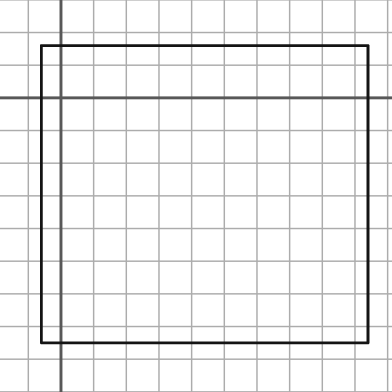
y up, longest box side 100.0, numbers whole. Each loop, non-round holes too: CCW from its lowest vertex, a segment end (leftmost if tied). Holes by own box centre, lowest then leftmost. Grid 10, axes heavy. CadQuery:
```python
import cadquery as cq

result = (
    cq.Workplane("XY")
    .moveTo(-6.0, -75.0)
    .lineTo(94.0, -75.0)
    .lineTo(94.0, 16.0)
    .lineTo(-6.0, 16.0)
    .close()
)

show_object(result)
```